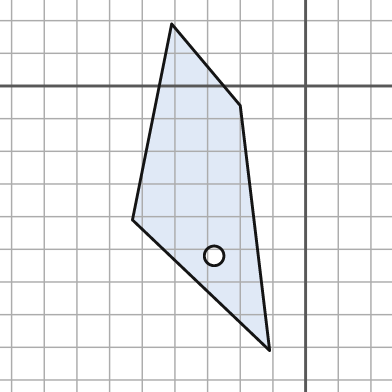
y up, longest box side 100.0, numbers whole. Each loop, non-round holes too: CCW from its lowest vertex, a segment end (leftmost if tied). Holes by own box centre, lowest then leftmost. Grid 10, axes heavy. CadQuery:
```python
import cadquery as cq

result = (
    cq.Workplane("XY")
    .moveTo(-11.0, -81.0)
    .lineTo(-20.0, -6.0)
    .lineTo(-41.0, 19.0)
    .lineTo(-53.0, -41.0)
    .close()
    .moveTo(-28.0, -52.0)
    .circle(3.0)
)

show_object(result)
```